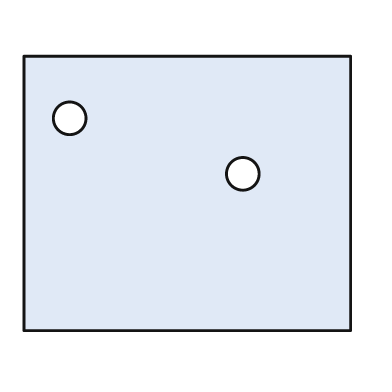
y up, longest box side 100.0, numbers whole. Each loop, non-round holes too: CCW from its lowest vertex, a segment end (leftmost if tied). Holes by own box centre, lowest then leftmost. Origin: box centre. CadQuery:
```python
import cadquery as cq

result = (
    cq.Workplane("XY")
    .moveTo(-50.0, -42.0)
    .lineTo(50.0, -42.0)
    .lineTo(50.0, 42.0)
    .lineTo(-50.0, 42.0)
    .close()
    .moveTo(17.0, 6.0)
    .circle(5.0)
    .moveTo(-36.0, 23.0)
    .circle(5.0)
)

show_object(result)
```